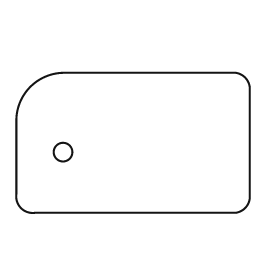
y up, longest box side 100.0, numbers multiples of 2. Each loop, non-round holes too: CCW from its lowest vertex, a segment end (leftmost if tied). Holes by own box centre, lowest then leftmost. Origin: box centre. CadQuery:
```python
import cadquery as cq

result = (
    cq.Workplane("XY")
    .moveTo(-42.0, -30.0)
    .lineTo(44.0, -30.0)
    .threePointArc((48.0, -28.0), (50.0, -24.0))
    .lineTo(50.0, 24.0)
    .threePointArc((48.0, 28.0), (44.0, 30.0))
    .lineTo(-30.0, 30.0)
    .threePointArc((-44.0, 24.0), (-50.0, 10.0))
    .lineTo(-50.0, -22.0)
    .threePointArc((-48.0, -28.0), (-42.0, -30.0))
    .close()
    .moveTo(-30.0, -4.0)
    .circle(4.0)
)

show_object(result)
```